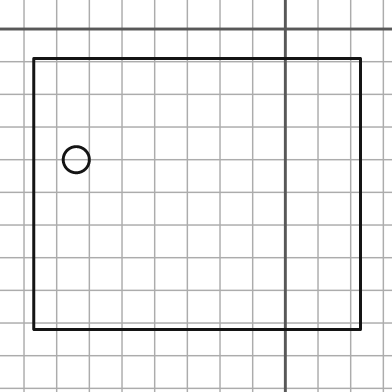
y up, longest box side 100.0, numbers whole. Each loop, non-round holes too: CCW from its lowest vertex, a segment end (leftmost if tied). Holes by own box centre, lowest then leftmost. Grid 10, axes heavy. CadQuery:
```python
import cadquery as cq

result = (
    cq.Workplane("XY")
    .moveTo(-77.0, -92.0)
    .lineTo(23.0, -92.0)
    .lineTo(23.0, -9.0)
    .lineTo(-77.0, -9.0)
    .close()
    .moveTo(-64.0, -40.0)
    .circle(4.0)
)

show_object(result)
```